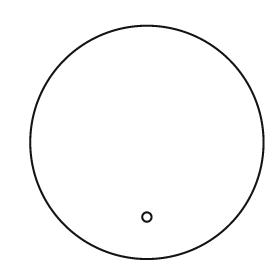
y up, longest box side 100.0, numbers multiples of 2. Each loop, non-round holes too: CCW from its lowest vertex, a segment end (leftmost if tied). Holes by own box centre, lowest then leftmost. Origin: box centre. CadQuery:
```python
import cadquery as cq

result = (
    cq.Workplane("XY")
    .moveTo(0.0, 0.0)
    .circle(50.0)
    .moveTo(0.0, -32.0)
    .circle(2.0)
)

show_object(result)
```